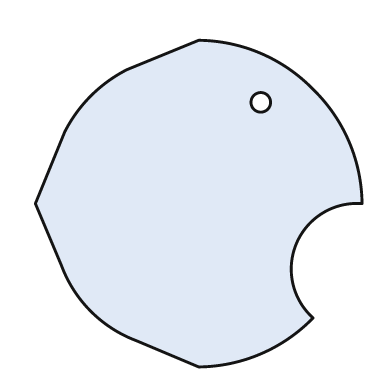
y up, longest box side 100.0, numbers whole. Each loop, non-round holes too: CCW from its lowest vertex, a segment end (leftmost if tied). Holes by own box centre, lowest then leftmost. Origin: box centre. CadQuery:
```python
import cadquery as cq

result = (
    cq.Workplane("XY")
    .moveTo(0.0, -50.0)
    .threePointArc((19.0, -46.0), (35.0, -35.0))
    .threePointArc((30.0, -12.0), (50.0, 0.0))
    .threePointArc((46.0, 19.0), (35.0, 35.0))
    .threePointArc((19.0, 46.0), (0.0, 50.0))
    .lineTo(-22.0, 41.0)
    .threePointArc((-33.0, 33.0), (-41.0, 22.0))
    .lineTo(-50.0, 0.0)
    .lineTo(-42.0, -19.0)
    .threePointArc((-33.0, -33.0), (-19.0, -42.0))
    .close()
    .moveTo(19.0, 31.0)
    .circle(3.0)
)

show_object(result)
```